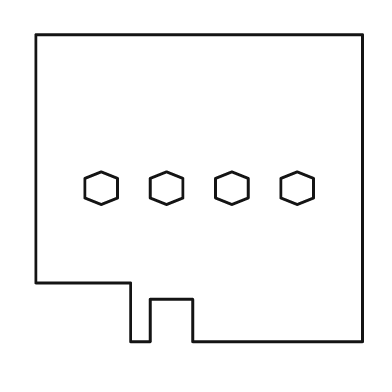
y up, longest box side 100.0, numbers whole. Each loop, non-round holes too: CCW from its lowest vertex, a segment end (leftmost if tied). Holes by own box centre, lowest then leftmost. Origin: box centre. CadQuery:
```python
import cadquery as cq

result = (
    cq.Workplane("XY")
    .moveTo(-21.0, -47.0)
    .lineTo(-15.0, -47.0)
    .lineTo(-15.0, -34.0)
    .lineTo(-2.0, -34.0)
    .lineTo(-2.0, -47.0)
    .lineTo(50.0, -47.0)
    .lineTo(50.0, 47.0)
    .lineTo(-50.0, 47.0)
    .lineTo(-50.0, -29.0)
    .lineTo(-21.0, -29.0)
    .close()
    .moveTo(-30.0, -5.0)
    .lineTo(-25.0, -3.0)
    .lineTo(-25.0, 3.0)
    .lineTo(-30.0, 5.0)
    .lineTo(-35.0, 3.0)
    .lineTo(-35.0, -3.0)
    .close()
    .moveTo(-10.0, -5.0)
    .lineTo(-5.0, -3.0)
    .lineTo(-5.0, 3.0)
    .lineTo(-10.0, 5.0)
    .lineTo(-15.0, 3.0)
    .lineTo(-15.0, -3.0)
    .close()
    .moveTo(10.0, -5.0)
    .lineTo(15.0, -3.0)
    .lineTo(15.0, 3.0)
    .lineTo(10.0, 5.0)
    .lineTo(5.0, 3.0)
    .lineTo(5.0, -3.0)
    .close()
    .moveTo(30.0, -5.0)
    .lineTo(35.0, -3.0)
    .lineTo(35.0, 3.0)
    .lineTo(30.0, 5.0)
    .lineTo(25.0, 3.0)
    .lineTo(25.0, -3.0)
    .close()
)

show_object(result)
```